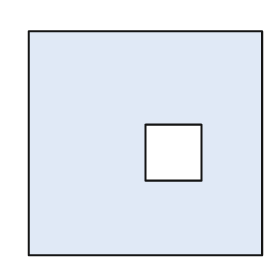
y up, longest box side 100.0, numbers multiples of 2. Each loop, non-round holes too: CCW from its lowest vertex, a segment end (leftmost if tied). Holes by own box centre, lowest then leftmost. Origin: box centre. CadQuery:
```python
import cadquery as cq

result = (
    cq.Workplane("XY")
    .moveTo(-50.0, -48.0)
    .lineTo(50.0, -48.0)
    .lineTo(50.0, 48.0)
    .lineTo(-50.0, 48.0)
    .close()
    .moveTo(0.0, -16.0)
    .lineTo(24.0, -16.0)
    .lineTo(24.0, 8.0)
    .lineTo(0.0, 8.0)
    .close()
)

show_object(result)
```